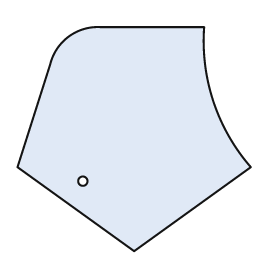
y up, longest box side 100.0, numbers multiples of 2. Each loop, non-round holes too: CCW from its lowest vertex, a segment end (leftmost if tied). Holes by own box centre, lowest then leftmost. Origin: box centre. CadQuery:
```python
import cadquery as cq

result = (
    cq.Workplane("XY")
    .moveTo(0.0, -48.0)
    .lineTo(50.0, -12.0)
    .threePointArc((34.0, 16.0), (30.0, 48.0))
    .lineTo(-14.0, 48.0)
    .threePointArc((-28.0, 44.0), (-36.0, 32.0))
    .lineTo(-50.0, -12.0)
    .close()
    .moveTo(-22.0, -18.0)
    .circle(2.0)
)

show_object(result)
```